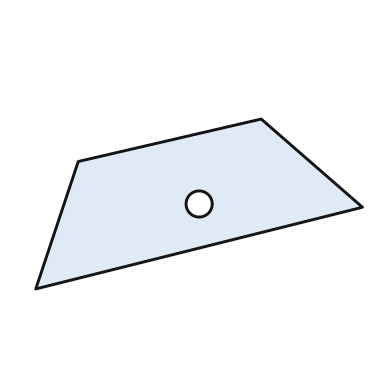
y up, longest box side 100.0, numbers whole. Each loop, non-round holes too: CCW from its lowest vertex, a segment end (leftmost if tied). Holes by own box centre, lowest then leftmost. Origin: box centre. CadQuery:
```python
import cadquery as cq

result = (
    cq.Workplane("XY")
    .moveTo(-50.0, -26.0)
    .lineTo(50.0, -1.0)
    .lineTo(19.0, 26.0)
    .lineTo(-37.0, 13.0)
    .close()
    .moveTo(0.0, 0.0)
    .circle(4.0)
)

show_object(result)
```